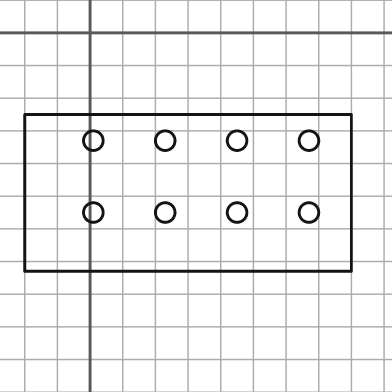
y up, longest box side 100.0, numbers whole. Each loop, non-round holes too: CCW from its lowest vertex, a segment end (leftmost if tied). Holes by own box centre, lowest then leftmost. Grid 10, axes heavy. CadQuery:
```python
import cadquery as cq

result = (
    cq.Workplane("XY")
    .moveTo(-20.0, -73.0)
    .lineTo(80.0, -73.0)
    .lineTo(80.0, -25.0)
    .lineTo(-20.0, -25.0)
    .close()
    .moveTo(1.0, -55.0)
    .circle(3.0)
    .moveTo(23.0, -55.0)
    .circle(3.0)
    .moveTo(45.0, -55.0)
    .circle(3.0)
    .moveTo(67.0, -55.0)
    .circle(3.0)
    .moveTo(1.0, -33.0)
    .circle(3.0)
    .moveTo(23.0, -33.0)
    .circle(3.0)
    .moveTo(45.0, -33.0)
    .circle(3.0)
    .moveTo(67.0, -33.0)
    .circle(3.0)
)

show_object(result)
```